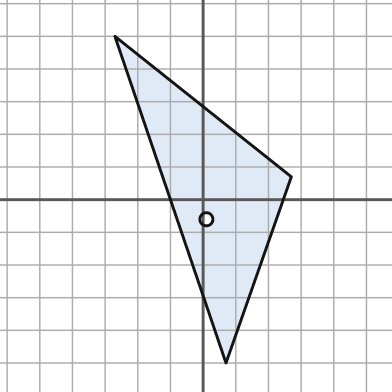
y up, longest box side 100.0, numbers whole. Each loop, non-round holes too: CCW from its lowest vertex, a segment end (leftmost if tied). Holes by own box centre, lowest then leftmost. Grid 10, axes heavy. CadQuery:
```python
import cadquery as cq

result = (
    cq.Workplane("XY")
    .moveTo(7.0, -50.0)
    .lineTo(27.0, 7.0)
    .lineTo(-27.0, 50.0)
    .close()
    .moveTo(1.0, -6.0)
    .circle(2.0)
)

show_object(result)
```